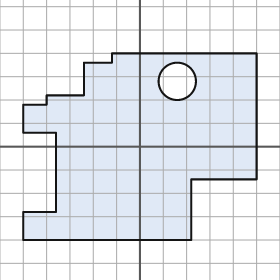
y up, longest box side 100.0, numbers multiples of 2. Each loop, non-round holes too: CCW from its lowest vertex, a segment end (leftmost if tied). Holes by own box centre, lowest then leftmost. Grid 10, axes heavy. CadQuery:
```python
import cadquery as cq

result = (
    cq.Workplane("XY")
    .moveTo(-50.0, -40.0)
    .lineTo(22.0, -40.0)
    .lineTo(22.0, -14.0)
    .lineTo(50.0, -14.0)
    .lineTo(50.0, 40.0)
    .lineTo(-12.0, 40.0)
    .lineTo(-12.0, 36.0)
    .lineTo(-24.0, 36.0)
    .lineTo(-24.0, 22.0)
    .lineTo(-40.0, 22.0)
    .lineTo(-40.0, 18.0)
    .lineTo(-50.0, 18.0)
    .lineTo(-50.0, 6.0)
    .lineTo(-36.0, 6.0)
    .lineTo(-36.0, -28.0)
    .lineTo(-50.0, -28.0)
    .close()
    .moveTo(16.0, 28.0)
    .circle(8.0)
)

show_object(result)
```